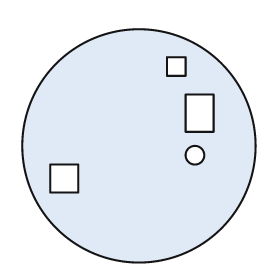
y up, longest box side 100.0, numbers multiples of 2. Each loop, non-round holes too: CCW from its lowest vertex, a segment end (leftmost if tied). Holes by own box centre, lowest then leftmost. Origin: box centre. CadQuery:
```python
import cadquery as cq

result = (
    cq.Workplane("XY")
    .moveTo(0.0, 0.0)
    .circle(50.0)
    .moveTo(-38.0, -20.0)
    .lineTo(-26.0, -20.0)
    .lineTo(-26.0, -8.0)
    .lineTo(-38.0, -8.0)
    .close()
    .moveTo(24.0, -4.0)
    .circle(4.0)
    .moveTo(20.0, 6.0)
    .lineTo(32.0, 6.0)
    .lineTo(32.0, 22.0)
    .lineTo(20.0, 22.0)
    .close()
    .moveTo(12.0, 30.0)
    .lineTo(20.0, 30.0)
    .lineTo(20.0, 38.0)
    .lineTo(12.0, 38.0)
    .close()
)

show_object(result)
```